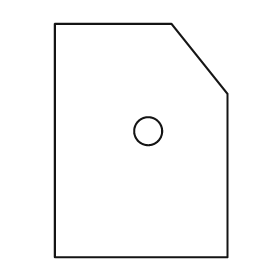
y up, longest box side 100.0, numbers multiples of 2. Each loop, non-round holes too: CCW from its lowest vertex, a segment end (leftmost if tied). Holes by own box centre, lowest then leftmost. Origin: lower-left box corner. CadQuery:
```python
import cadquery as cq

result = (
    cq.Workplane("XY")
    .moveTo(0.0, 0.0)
    .lineTo(74.0, 0.0)
    .lineTo(74.0, 70.0)
    .lineTo(50.0, 100.0)
    .lineTo(0.0, 100.0)
    .close()
    .moveTo(40.0, 54.0)
    .circle(6.0)
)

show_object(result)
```